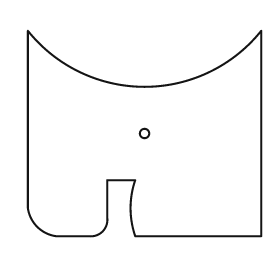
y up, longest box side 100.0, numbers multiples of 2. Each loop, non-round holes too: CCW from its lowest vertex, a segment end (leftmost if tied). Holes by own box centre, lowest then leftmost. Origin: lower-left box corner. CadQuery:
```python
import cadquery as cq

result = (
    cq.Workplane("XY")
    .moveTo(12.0, 0.0)
    .lineTo(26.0, 0.0)
    .threePointArc((32.0, 2.0), (34.0, 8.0))
    .lineTo(34.0, 24.0)
    .lineTo(46.0, 24.0)
    .threePointArc((44.0, 12.0), (46.0, 0.0))
    .lineTo(100.0, 0.0)
    .lineTo(100.0, 88.0)
    .threePointArc((50.0, 64.0), (0.0, 88.0))
    .lineTo(0.0, 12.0)
    .threePointArc((4.0, 4.0), (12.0, 0.0))
    .close()
    .moveTo(50.0, 44.0)
    .circle(2.0)
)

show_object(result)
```